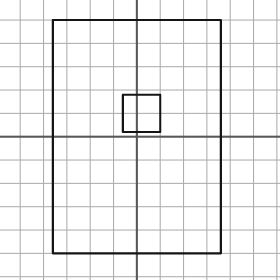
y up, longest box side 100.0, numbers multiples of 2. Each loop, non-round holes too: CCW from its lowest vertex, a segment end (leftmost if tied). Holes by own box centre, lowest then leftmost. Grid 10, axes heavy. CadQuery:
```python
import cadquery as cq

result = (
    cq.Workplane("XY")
    .moveTo(-36.0, -50.0)
    .lineTo(36.0, -50.0)
    .lineTo(36.0, 50.0)
    .lineTo(-36.0, 50.0)
    .close()
    .moveTo(-6.0, 2.0)
    .lineTo(10.0, 2.0)
    .lineTo(10.0, 18.0)
    .lineTo(-6.0, 18.0)
    .close()
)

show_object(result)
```